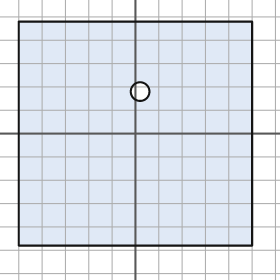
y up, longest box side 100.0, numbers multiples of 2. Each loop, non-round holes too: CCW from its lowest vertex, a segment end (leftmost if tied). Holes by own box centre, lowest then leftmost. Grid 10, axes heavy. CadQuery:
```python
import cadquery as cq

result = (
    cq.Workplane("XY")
    .moveTo(-50.0, -48.0)
    .lineTo(50.0, -48.0)
    .lineTo(50.0, 48.0)
    .lineTo(-50.0, 48.0)
    .close()
    .moveTo(2.0, 18.0)
    .circle(4.0)
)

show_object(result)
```